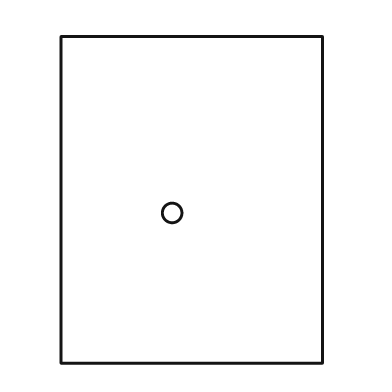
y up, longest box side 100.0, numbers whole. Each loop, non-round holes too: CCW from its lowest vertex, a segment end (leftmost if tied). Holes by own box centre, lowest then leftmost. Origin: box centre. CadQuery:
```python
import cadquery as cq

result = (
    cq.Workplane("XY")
    .moveTo(-40.0, -50.0)
    .lineTo(40.0, -50.0)
    .lineTo(40.0, 50.0)
    .lineTo(-40.0, 50.0)
    .close()
    .moveTo(-6.0, -4.0)
    .circle(3.0)
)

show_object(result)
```